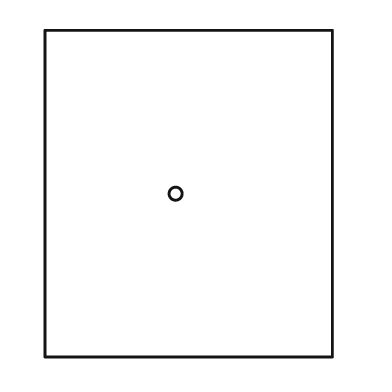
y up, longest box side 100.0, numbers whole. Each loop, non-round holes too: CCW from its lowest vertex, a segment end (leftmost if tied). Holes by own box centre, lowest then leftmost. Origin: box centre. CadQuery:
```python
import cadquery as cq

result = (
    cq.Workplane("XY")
    .moveTo(-44.0, -50.0)
    .lineTo(44.0, -50.0)
    .lineTo(44.0, 50.0)
    .lineTo(-44.0, 50.0)
    .close()
    .moveTo(-4.0, 0.0)
    .circle(2.0)
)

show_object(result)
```